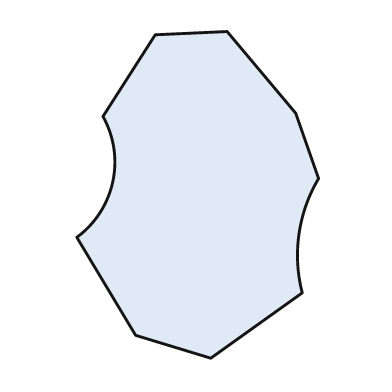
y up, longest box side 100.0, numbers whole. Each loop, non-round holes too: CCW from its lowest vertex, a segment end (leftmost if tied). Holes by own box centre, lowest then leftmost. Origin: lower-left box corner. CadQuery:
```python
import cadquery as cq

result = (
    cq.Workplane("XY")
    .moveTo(41.0, 0.0)
    .lineTo(69.0, 20.0)
    .threePointArc((68.0, 38.0), (74.0, 55.0))
    .lineTo(67.0, 75.0)
    .lineTo(46.0, 100.0)
    .lineTo(24.0, 99.0)
    .lineTo(8.0, 74.0)
    .threePointArc((11.0, 54.0), (0.0, 37.0))
    .lineTo(18.0, 7.0)
    .close()
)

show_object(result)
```